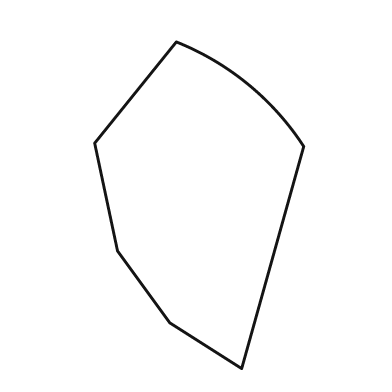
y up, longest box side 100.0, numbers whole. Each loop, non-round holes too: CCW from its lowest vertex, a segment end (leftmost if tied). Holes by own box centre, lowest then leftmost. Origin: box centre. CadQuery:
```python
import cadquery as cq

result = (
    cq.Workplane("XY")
    .moveTo(13.0, -50.0)
    .lineTo(32.0, 18.0)
    .threePointArc((15.0, 37.0), (-7.0, 50.0))
    .lineTo(-32.0, 19.0)
    .lineTo(-25.0, -14.0)
    .lineTo(-9.0, -36.0)
    .close()
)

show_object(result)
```